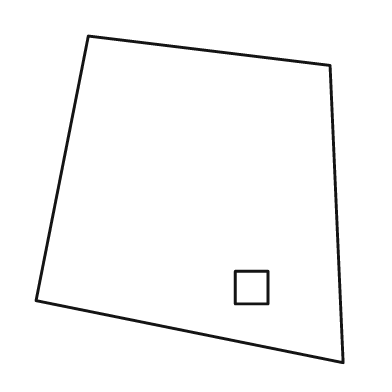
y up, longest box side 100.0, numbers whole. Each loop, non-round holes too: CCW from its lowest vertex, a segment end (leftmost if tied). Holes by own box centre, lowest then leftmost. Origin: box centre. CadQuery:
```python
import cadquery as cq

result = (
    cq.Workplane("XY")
    .moveTo(47.0, -50.0)
    .lineTo(43.0, 41.0)
    .lineTo(-31.0, 50.0)
    .lineTo(-47.0, -31.0)
    .close()
    .moveTo(14.0, -32.0)
    .lineTo(24.0, -32.0)
    .lineTo(24.0, -22.0)
    .lineTo(14.0, -22.0)
    .close()
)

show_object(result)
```